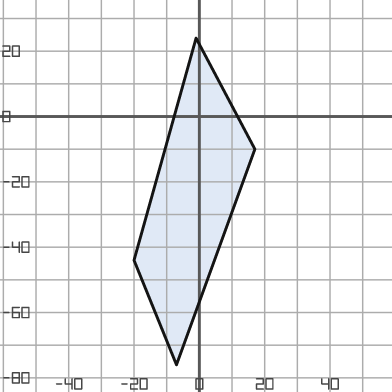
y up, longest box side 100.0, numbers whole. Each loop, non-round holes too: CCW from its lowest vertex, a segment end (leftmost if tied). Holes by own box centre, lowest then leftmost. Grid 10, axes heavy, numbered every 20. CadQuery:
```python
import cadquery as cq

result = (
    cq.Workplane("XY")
    .moveTo(-7.0, -76.0)
    .lineTo(17.0, -10.0)
    .lineTo(-1.0, 24.0)
    .lineTo(-20.0, -44.0)
    .close()
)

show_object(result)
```